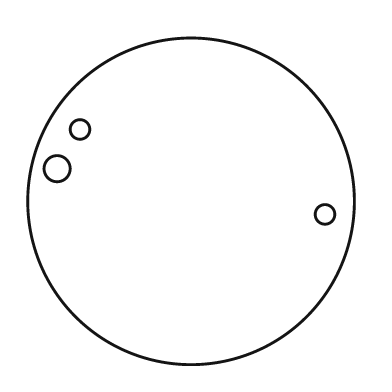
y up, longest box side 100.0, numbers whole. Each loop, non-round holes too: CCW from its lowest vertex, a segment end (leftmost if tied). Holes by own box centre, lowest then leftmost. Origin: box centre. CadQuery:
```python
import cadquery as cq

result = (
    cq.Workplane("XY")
    .moveTo(0.0, 0.0)
    .circle(50.0)
    .moveTo(41.0, -4.0)
    .circle(3.0)
    .moveTo(-41.0, 10.0)
    .circle(4.0)
    .moveTo(-34.0, 22.0)
    .circle(3.0)
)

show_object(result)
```